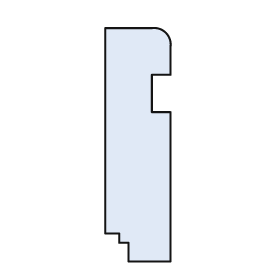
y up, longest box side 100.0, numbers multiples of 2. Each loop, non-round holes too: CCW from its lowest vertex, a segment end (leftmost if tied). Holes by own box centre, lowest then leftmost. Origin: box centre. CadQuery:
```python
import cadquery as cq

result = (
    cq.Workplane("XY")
    .moveTo(-4.0, -50.0)
    .lineTo(14.0, -50.0)
    .lineTo(14.0, 14.0)
    .lineTo(6.0, 14.0)
    .lineTo(6.0, 30.0)
    .lineTo(14.0, 30.0)
    .lineTo(14.0, 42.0)
    .threePointArc((12.0, 48.0), (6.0, 50.0))
    .lineTo(-14.0, 50.0)
    .lineTo(-14.0, -38.0)
    .lineTo(-8.0, -38.0)
    .lineTo(-8.0, -42.0)
    .lineTo(-4.0, -42.0)
    .close()
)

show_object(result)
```